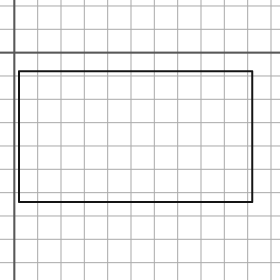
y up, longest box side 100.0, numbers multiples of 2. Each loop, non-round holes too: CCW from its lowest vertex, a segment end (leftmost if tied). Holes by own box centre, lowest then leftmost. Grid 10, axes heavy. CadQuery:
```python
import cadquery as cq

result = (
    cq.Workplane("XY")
    .moveTo(2.0, -64.0)
    .lineTo(102.0, -64.0)
    .lineTo(102.0, -8.0)
    .lineTo(2.0, -8.0)
    .close()
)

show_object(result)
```